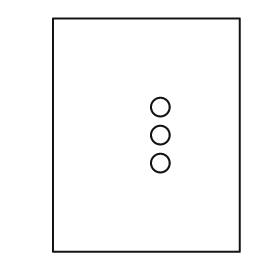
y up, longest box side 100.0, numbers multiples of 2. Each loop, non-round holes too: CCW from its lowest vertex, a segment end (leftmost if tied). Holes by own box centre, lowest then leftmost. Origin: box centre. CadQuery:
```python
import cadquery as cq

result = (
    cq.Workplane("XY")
    .moveTo(-40.0, -50.0)
    .lineTo(40.0, -50.0)
    .lineTo(40.0, 50.0)
    .lineTo(-40.0, 50.0)
    .close()
    .moveTo(6.0, -12.0)
    .circle(4.0)
    .moveTo(6.0, 0.0)
    .circle(4.0)
    .moveTo(6.0, 12.0)
    .circle(4.0)
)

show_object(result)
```